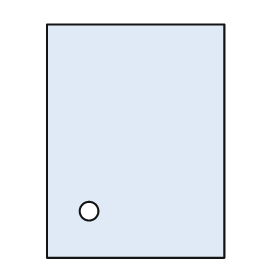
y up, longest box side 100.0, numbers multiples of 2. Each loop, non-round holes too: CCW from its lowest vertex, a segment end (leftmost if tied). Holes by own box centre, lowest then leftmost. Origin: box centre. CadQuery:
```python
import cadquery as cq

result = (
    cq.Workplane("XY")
    .moveTo(-38.0, -50.0)
    .lineTo(38.0, -50.0)
    .lineTo(38.0, 50.0)
    .lineTo(-38.0, 50.0)
    .close()
    .moveTo(-20.0, -30.0)
    .circle(4.0)
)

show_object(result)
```